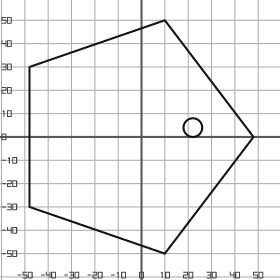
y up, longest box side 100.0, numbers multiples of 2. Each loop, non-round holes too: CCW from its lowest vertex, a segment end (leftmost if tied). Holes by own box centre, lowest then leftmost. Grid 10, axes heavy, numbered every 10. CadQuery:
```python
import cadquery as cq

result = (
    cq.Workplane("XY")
    .moveTo(10.0, -50.0)
    .lineTo(48.0, 0.0)
    .lineTo(10.0, 50.0)
    .lineTo(-48.0, 30.0)
    .lineTo(-48.0, -30.0)
    .close()
    .moveTo(22.0, 4.0)
    .circle(4.0)
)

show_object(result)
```